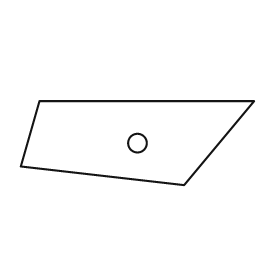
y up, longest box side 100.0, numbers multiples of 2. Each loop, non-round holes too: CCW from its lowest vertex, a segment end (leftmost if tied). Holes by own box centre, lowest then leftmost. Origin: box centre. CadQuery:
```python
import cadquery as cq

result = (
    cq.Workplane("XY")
    .moveTo(20.0, -18.0)
    .lineTo(50.0, 18.0)
    .lineTo(-42.0, 18.0)
    .lineTo(-50.0, -10.0)
    .close()
    .moveTo(0.0, 0.0)
    .circle(4.0)
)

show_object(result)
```